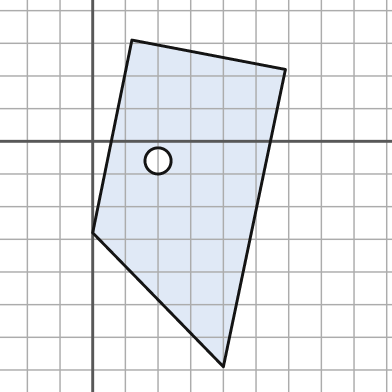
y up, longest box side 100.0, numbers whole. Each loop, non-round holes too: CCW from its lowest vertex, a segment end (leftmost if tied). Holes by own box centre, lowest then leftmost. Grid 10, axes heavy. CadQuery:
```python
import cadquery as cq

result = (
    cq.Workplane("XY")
    .moveTo(40.0, -69.0)
    .lineTo(59.0, 22.0)
    .lineTo(12.0, 31.0)
    .lineTo(0.0, -28.0)
    .close()
    .moveTo(20.0, -6.0)
    .circle(4.0)
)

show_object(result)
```